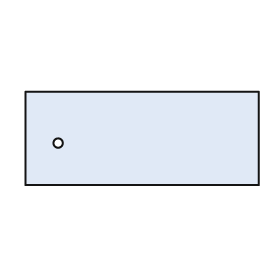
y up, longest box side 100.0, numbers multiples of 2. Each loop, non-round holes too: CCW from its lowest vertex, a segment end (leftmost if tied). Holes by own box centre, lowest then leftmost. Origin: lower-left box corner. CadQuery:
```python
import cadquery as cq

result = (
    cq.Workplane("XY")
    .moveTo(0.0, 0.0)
    .lineTo(100.0, 0.0)
    .lineTo(100.0, 40.0)
    .lineTo(0.0, 40.0)
    .close()
    .moveTo(14.0, 18.0)
    .circle(2.0)
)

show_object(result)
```